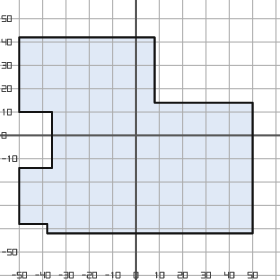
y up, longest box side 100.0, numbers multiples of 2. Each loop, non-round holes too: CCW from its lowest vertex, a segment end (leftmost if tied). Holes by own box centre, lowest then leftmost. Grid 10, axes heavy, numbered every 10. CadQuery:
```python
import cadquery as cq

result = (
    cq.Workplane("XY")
    .moveTo(-38.0, -42.0)
    .lineTo(50.0, -42.0)
    .lineTo(50.0, 14.0)
    .lineTo(8.0, 14.0)
    .lineTo(8.0, 42.0)
    .lineTo(-50.0, 42.0)
    .lineTo(-50.0, 10.0)
    .lineTo(-36.0, 10.0)
    .lineTo(-36.0, -14.0)
    .lineTo(-50.0, -14.0)
    .lineTo(-50.0, -38.0)
    .lineTo(-38.0, -38.0)
    .close()
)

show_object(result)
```